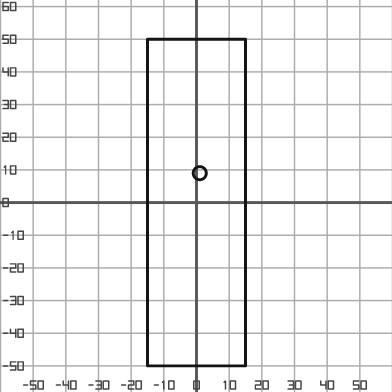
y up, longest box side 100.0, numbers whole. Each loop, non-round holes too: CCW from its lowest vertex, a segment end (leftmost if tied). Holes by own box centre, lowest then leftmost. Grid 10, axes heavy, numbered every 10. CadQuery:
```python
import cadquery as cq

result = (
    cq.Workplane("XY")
    .moveTo(-15.0, -50.0)
    .lineTo(15.0, -50.0)
    .lineTo(15.0, 50.0)
    .lineTo(-15.0, 50.0)
    .close()
    .moveTo(1.0, 9.0)
    .circle(2.0)
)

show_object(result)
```